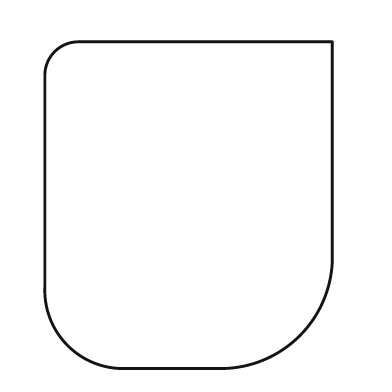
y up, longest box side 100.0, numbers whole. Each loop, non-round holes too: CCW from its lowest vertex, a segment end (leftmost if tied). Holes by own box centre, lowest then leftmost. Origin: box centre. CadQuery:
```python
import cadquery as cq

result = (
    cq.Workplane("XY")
    .moveTo(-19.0, -50.0)
    .lineTo(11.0, -50.0)
    .threePointArc((34.0, -40.0), (44.0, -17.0))
    .lineTo(44.0, 50.0)
    .lineTo(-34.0, 50.0)
    .threePointArc((-41.0, 47.0), (-44.0, 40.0))
    .lineTo(-44.0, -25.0)
    .threePointArc((-37.0, -43.0), (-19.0, -50.0))
    .close()
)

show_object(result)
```